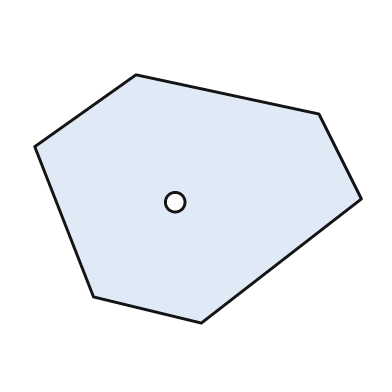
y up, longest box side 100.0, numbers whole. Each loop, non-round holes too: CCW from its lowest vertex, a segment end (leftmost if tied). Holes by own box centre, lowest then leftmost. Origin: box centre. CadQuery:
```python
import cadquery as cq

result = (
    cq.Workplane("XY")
    .moveTo(1.0, -38.0)
    .lineTo(50.0, 0.0)
    .lineTo(37.0, 26.0)
    .lineTo(-19.0, 38.0)
    .lineTo(-50.0, 16.0)
    .lineTo(-32.0, -30.0)
    .close()
    .moveTo(-7.0, -1.0)
    .circle(3.0)
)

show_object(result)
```